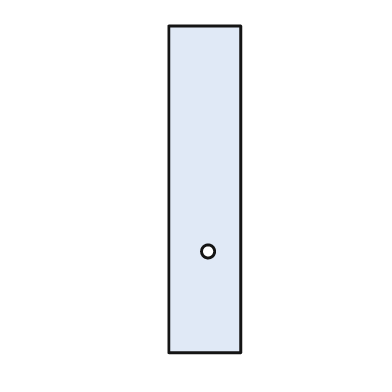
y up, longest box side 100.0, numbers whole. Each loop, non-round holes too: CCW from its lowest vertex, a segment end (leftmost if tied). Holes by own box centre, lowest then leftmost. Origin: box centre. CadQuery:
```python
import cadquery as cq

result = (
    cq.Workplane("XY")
    .moveTo(-11.0, -50.0)
    .lineTo(11.0, -50.0)
    .lineTo(11.0, 50.0)
    .lineTo(-11.0, 50.0)
    .close()
    .moveTo(1.0, -19.0)
    .circle(2.0)
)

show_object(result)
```